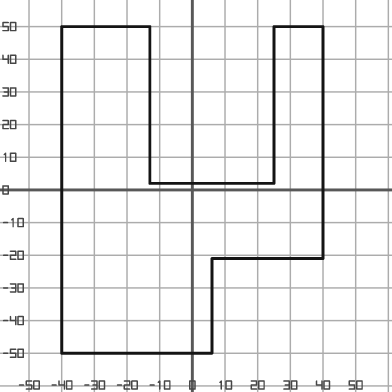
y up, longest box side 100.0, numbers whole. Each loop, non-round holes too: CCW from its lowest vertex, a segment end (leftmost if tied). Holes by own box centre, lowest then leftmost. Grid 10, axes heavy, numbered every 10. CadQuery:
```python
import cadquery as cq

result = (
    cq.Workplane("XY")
    .moveTo(-40.0, -50.0)
    .lineTo(6.0, -50.0)
    .lineTo(6.0, -21.0)
    .lineTo(40.0, -21.0)
    .lineTo(40.0, 50.0)
    .lineTo(25.0, 50.0)
    .lineTo(25.0, 2.0)
    .lineTo(-13.0, 2.0)
    .lineTo(-13.0, 50.0)
    .lineTo(-40.0, 50.0)
    .close()
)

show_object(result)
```